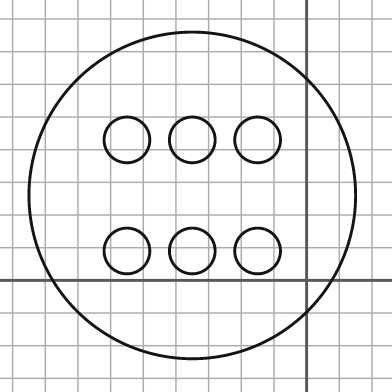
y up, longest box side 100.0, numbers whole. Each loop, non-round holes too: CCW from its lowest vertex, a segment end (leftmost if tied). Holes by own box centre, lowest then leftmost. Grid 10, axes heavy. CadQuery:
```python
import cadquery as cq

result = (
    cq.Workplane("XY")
    .moveTo(-35.0, 26.0)
    .circle(50.0)
    .moveTo(-55.0, 9.0)
    .circle(7.0)
    .moveTo(-35.0, 9.0)
    .circle(7.0)
    .moveTo(-15.0, 9.0)
    .circle(7.0)
    .moveTo(-55.0, 43.0)
    .circle(7.0)
    .moveTo(-35.0, 43.0)
    .circle(7.0)
    .moveTo(-15.0, 43.0)
    .circle(7.0)
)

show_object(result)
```